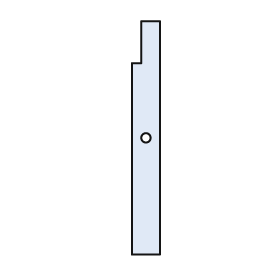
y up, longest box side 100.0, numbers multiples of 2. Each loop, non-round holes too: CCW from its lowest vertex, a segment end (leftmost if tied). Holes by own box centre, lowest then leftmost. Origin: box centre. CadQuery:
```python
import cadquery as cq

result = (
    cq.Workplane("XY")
    .moveTo(-6.0, -50.0)
    .lineTo(6.0, -50.0)
    .lineTo(6.0, 50.0)
    .lineTo(-2.0, 50.0)
    .lineTo(-2.0, 32.0)
    .lineTo(-6.0, 32.0)
    .close()
    .moveTo(0.0, 0.0)
    .circle(2.0)
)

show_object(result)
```